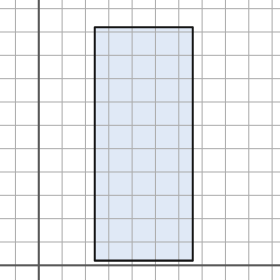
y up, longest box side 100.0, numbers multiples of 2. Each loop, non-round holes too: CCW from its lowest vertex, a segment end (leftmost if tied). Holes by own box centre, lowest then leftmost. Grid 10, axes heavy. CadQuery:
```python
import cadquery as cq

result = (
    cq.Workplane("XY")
    .moveTo(24.0, 2.0)
    .lineTo(66.0, 2.0)
    .lineTo(66.0, 102.0)
    .lineTo(24.0, 102.0)
    .close()
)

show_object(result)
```